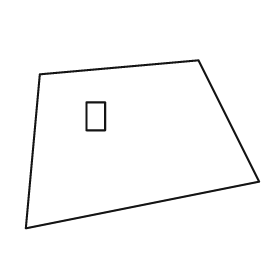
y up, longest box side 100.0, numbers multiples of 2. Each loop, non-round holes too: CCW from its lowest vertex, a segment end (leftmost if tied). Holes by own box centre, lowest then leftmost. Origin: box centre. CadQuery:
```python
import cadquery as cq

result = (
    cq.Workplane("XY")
    .moveTo(-50.0, -36.0)
    .lineTo(50.0, -16.0)
    .lineTo(24.0, 36.0)
    .lineTo(-44.0, 30.0)
    .close()
    .moveTo(-24.0, 6.0)
    .lineTo(-16.0, 6.0)
    .lineTo(-16.0, 18.0)
    .lineTo(-24.0, 18.0)
    .close()
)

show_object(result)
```